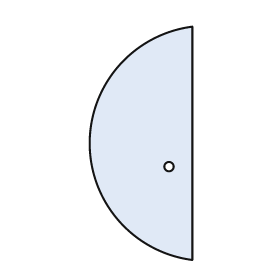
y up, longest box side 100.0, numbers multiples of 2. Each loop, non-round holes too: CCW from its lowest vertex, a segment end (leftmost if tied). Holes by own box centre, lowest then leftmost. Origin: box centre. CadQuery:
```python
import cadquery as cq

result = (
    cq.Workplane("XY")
    .moveTo(22.0, -50.0)
    .lineTo(22.0, 50.0)
    .threePointArc((-22.0, 0.0), (22.0, -50.0))
    .close()
    .moveTo(12.0, -10.0)
    .circle(2.0)
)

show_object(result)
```